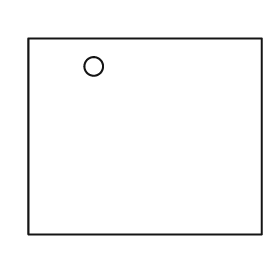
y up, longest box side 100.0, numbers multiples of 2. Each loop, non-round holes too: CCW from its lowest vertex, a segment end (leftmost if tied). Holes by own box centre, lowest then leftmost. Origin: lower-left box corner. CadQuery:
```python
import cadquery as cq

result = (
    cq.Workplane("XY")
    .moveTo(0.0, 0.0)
    .lineTo(100.0, 0.0)
    .lineTo(100.0, 84.0)
    .lineTo(0.0, 84.0)
    .close()
    .moveTo(28.0, 72.0)
    .circle(4.0)
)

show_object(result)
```